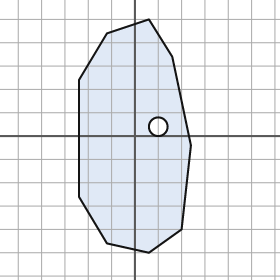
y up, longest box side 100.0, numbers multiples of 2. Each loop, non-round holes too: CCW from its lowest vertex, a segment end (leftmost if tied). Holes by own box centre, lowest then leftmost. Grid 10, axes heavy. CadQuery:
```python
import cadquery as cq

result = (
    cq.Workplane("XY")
    .moveTo(6.0, -50.0)
    .lineTo(20.0, -40.0)
    .lineTo(24.0, -4.0)
    .lineTo(16.0, 34.0)
    .lineTo(6.0, 50.0)
    .lineTo(-12.0, 44.0)
    .lineTo(-24.0, 24.0)
    .lineTo(-24.0, -26.0)
    .lineTo(-12.0, -46.0)
    .close()
    .moveTo(10.0, 4.0)
    .circle(4.0)
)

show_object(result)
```